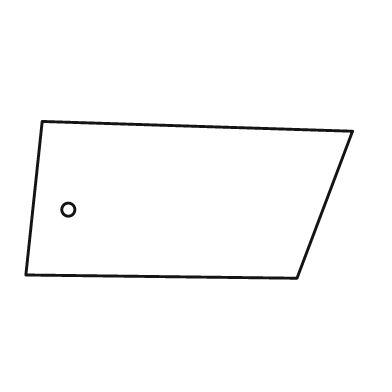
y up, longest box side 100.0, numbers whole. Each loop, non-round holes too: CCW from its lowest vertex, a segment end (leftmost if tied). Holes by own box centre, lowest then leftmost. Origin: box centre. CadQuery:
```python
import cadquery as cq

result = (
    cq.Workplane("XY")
    .moveTo(33.0, -24.0)
    .lineTo(50.0, 21.0)
    .lineTo(-45.0, 24.0)
    .lineTo(-50.0, -23.0)
    .close()
    .moveTo(-37.0, -3.0)
    .circle(2.0)
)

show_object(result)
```